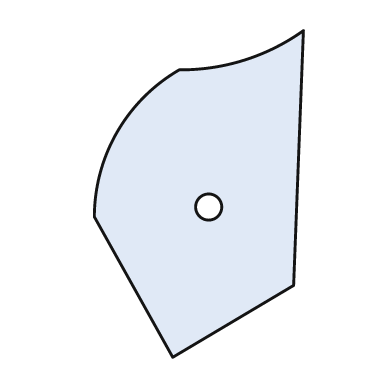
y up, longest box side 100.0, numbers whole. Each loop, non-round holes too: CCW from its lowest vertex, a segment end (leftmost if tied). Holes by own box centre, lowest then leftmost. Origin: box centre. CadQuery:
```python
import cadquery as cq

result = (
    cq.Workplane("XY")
    .moveTo(-8.0, -50.0)
    .lineTo(29.0, -28.0)
    .lineTo(32.0, 50.0)
    .threePointArc((14.0, 41.0), (-6.0, 38.0))
    .threePointArc((-25.0, 19.0), (-32.0, -7.0))
    .close()
    .moveTo(3.0, -4.0)
    .circle(4.0)
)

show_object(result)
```